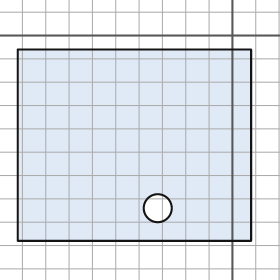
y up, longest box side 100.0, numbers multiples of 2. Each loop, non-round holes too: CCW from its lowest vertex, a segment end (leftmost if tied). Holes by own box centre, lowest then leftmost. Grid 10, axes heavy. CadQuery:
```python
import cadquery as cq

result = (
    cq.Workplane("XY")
    .moveTo(-92.0, -88.0)
    .lineTo(8.0, -88.0)
    .lineTo(8.0, -6.0)
    .lineTo(-92.0, -6.0)
    .close()
    .moveTo(-32.0, -74.0)
    .circle(6.0)
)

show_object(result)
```